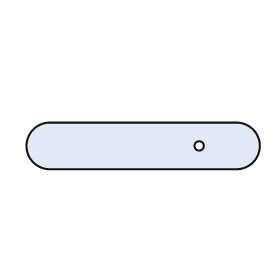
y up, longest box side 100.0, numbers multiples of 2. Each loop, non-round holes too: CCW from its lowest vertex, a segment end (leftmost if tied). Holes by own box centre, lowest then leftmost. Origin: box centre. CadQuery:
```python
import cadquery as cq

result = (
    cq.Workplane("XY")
    .moveTo(-40.0, -10.0)
    .lineTo(40.0, -10.0)
    .threePointArc((50.0, 0.0), (40.0, 10.0))
    .lineTo(-40.0, 10.0)
    .threePointArc((-50.0, 0.0), (-40.0, -10.0))
    .close()
    .moveTo(24.0, 0.0)
    .circle(2.0)
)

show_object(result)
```